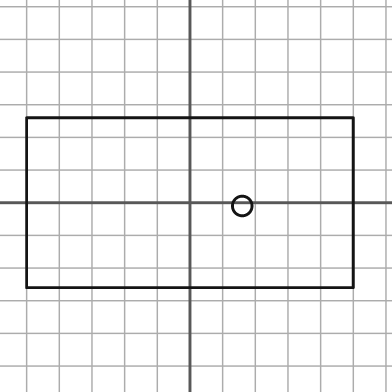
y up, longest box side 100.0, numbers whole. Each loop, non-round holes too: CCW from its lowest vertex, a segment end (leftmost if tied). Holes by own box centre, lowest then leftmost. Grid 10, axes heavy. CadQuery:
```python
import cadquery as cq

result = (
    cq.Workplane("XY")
    .moveTo(-50.0, -26.0)
    .lineTo(50.0, -26.0)
    .lineTo(50.0, 26.0)
    .lineTo(-50.0, 26.0)
    .close()
    .moveTo(16.0, -1.0)
    .circle(3.0)
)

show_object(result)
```